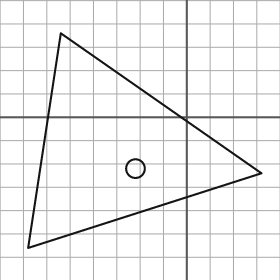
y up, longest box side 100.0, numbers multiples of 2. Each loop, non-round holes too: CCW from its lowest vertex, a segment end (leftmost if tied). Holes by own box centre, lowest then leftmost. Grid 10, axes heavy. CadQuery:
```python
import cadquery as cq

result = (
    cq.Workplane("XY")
    .moveTo(-68.0, -56.0)
    .lineTo(32.0, -24.0)
    .lineTo(-54.0, 36.0)
    .close()
    .moveTo(-22.0, -22.0)
    .circle(4.0)
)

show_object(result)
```